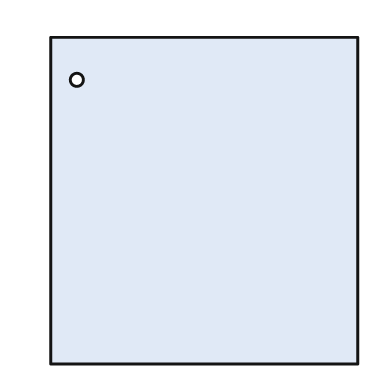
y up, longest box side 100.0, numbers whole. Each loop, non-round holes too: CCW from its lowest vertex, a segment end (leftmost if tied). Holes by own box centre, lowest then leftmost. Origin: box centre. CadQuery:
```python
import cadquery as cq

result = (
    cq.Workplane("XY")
    .moveTo(-47.0, -50.0)
    .lineTo(47.0, -50.0)
    .lineTo(47.0, 50.0)
    .lineTo(-47.0, 50.0)
    .close()
    .moveTo(-39.0, 37.0)
    .circle(2.0)
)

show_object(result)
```